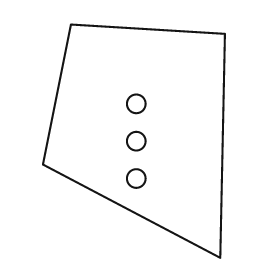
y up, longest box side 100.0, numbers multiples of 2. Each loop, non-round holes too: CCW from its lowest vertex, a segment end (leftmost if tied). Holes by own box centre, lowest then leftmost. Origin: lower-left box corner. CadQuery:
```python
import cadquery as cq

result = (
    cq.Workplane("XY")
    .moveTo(76.0, 0.0)
    .lineTo(78.0, 96.0)
    .lineTo(12.0, 100.0)
    .lineTo(0.0, 40.0)
    .close()
    .moveTo(40.0, 34.0)
    .circle(4.0)
    .moveTo(40.0, 50.0)
    .circle(4.0)
    .moveTo(40.0, 66.0)
    .circle(4.0)
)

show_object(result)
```